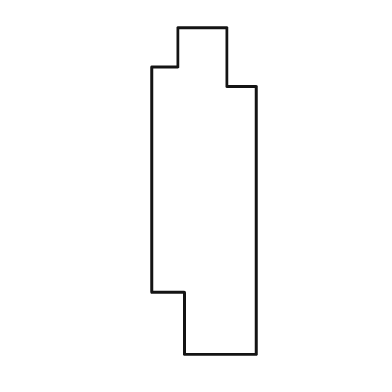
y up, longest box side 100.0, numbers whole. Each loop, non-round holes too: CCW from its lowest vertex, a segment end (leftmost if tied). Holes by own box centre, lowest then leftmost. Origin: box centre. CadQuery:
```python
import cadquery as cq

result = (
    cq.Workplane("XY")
    .moveTo(-6.0, -50.0)
    .lineTo(16.0, -50.0)
    .lineTo(16.0, 32.0)
    .lineTo(7.0, 32.0)
    .lineTo(7.0, 50.0)
    .lineTo(-8.0, 50.0)
    .lineTo(-8.0, 38.0)
    .lineTo(-16.0, 38.0)
    .lineTo(-16.0, -31.0)
    .lineTo(-6.0, -31.0)
    .close()
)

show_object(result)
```